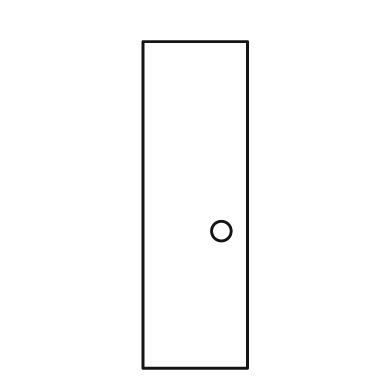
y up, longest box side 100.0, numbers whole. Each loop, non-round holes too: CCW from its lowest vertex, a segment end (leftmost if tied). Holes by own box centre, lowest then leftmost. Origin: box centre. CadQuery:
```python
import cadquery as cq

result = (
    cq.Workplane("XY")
    .moveTo(-16.0, -50.0)
    .lineTo(16.0, -50.0)
    .lineTo(16.0, 50.0)
    .lineTo(-16.0, 50.0)
    .close()
    .moveTo(8.0, -8.0)
    .circle(3.0)
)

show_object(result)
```